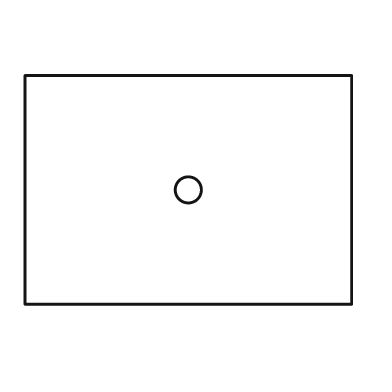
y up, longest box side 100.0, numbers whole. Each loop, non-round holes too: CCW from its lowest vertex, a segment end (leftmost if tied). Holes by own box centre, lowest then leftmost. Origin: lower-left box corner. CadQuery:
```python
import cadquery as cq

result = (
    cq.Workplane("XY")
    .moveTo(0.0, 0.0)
    .lineTo(100.0, 0.0)
    .lineTo(100.0, 70.0)
    .lineTo(0.0, 70.0)
    .close()
    .moveTo(50.0, 35.0)
    .circle(4.0)
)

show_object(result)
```